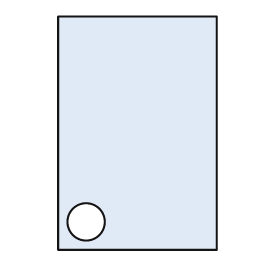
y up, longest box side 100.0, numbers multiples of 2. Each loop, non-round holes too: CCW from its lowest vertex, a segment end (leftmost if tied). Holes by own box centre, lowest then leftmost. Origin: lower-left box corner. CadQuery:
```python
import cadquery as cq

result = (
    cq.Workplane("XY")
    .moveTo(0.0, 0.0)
    .lineTo(68.0, 0.0)
    .lineTo(68.0, 100.0)
    .lineTo(0.0, 100.0)
    .close()
    .moveTo(12.0, 12.0)
    .circle(8.0)
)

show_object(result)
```